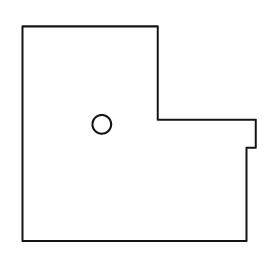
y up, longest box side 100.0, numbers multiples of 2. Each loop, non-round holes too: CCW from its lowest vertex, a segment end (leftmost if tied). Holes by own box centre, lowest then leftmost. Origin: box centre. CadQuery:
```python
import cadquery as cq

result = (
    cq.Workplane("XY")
    .moveTo(-50.0, -46.0)
    .lineTo(46.0, -46.0)
    .lineTo(46.0, -6.0)
    .lineTo(50.0, -6.0)
    .lineTo(50.0, 6.0)
    .lineTo(8.0, 6.0)
    .lineTo(8.0, 46.0)
    .lineTo(-50.0, 46.0)
    .close()
    .moveTo(-16.0, 4.0)
    .circle(4.0)
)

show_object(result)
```